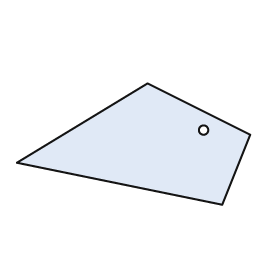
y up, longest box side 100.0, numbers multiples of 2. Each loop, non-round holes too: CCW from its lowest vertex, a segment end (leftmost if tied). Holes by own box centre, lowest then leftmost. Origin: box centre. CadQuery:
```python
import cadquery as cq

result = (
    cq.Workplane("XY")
    .moveTo(38.0, -26.0)
    .lineTo(50.0, 4.0)
    .lineTo(6.0, 26.0)
    .lineTo(-50.0, -8.0)
    .close()
    .moveTo(30.0, 6.0)
    .circle(2.0)
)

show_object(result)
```